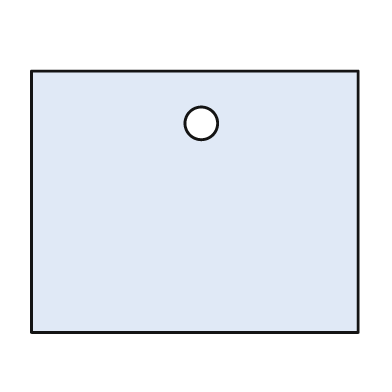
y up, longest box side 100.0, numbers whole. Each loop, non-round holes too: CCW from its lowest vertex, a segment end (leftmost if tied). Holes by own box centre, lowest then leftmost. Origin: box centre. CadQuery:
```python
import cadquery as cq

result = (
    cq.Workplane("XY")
    .moveTo(-50.0, -40.0)
    .lineTo(50.0, -40.0)
    .lineTo(50.0, 40.0)
    .lineTo(-50.0, 40.0)
    .close()
    .moveTo(2.0, 24.0)
    .circle(5.0)
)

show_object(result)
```